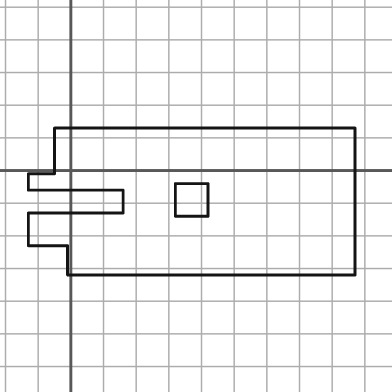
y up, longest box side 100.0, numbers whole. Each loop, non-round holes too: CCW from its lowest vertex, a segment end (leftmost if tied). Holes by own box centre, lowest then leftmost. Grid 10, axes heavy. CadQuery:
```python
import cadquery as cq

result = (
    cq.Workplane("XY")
    .moveTo(-1.0, -32.0)
    .lineTo(87.0, -32.0)
    .lineTo(87.0, 13.0)
    .lineTo(-5.0, 13.0)
    .lineTo(-5.0, -1.0)
    .lineTo(-13.0, -1.0)
    .lineTo(-13.0, -6.0)
    .lineTo(16.0, -6.0)
    .lineTo(16.0, -13.0)
    .lineTo(-13.0, -13.0)
    .lineTo(-13.0, -23.0)
    .lineTo(-1.0, -23.0)
    .close()
    .moveTo(32.0, -14.0)
    .lineTo(42.0, -14.0)
    .lineTo(42.0, -4.0)
    .lineTo(32.0, -4.0)
    .close()
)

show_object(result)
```